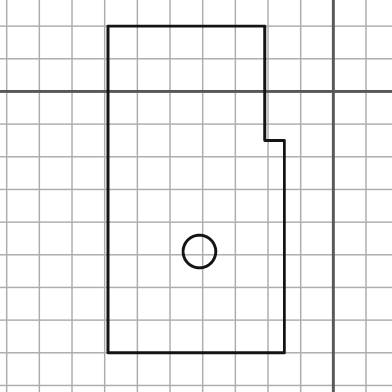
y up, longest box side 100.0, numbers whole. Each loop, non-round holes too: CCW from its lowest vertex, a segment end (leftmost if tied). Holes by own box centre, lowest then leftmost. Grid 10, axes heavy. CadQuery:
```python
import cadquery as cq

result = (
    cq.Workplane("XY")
    .moveTo(-69.0, -80.0)
    .lineTo(-15.0, -80.0)
    .lineTo(-15.0, -15.0)
    .lineTo(-21.0, -15.0)
    .lineTo(-21.0, 20.0)
    .lineTo(-69.0, 20.0)
    .close()
    .moveTo(-41.0, -49.0)
    .circle(5.0)
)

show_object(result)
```